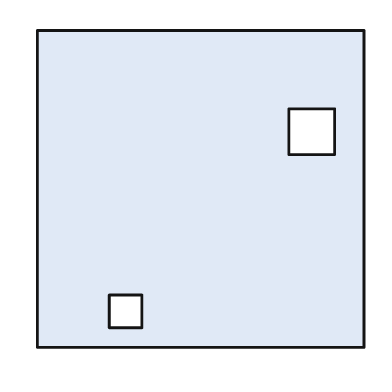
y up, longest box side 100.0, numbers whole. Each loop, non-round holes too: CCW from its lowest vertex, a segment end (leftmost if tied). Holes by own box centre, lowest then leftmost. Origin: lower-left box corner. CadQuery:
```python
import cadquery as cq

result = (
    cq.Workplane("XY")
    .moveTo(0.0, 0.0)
    .lineTo(100.0, 0.0)
    .lineTo(100.0, 97.0)
    .lineTo(0.0, 97.0)
    .close()
    .moveTo(22.0, 6.0)
    .lineTo(32.0, 6.0)
    .lineTo(32.0, 16.0)
    .lineTo(22.0, 16.0)
    .close()
    .moveTo(77.0, 59.0)
    .lineTo(91.0, 59.0)
    .lineTo(91.0, 73.0)
    .lineTo(77.0, 73.0)
    .close()
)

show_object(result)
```